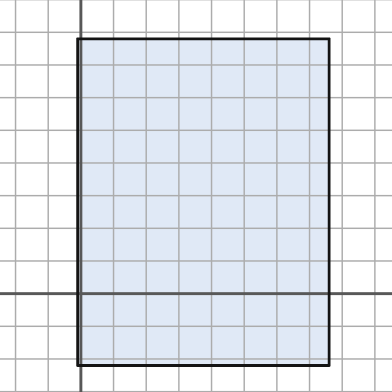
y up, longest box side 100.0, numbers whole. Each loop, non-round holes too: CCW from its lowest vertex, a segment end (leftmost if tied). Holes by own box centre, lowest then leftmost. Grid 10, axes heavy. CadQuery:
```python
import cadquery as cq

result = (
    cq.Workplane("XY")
    .moveTo(-1.0, -22.0)
    .lineTo(76.0, -22.0)
    .lineTo(76.0, 78.0)
    .lineTo(-1.0, 78.0)
    .close()
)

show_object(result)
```